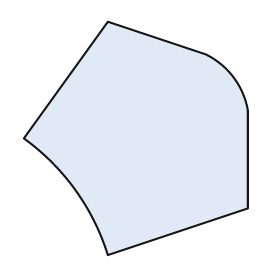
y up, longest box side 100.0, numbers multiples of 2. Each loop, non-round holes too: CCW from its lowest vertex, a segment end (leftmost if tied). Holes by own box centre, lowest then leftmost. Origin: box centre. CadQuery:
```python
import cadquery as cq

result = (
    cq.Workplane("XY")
    .moveTo(-12.0, -50.0)
    .lineTo(48.0, -30.0)
    .lineTo(48.0, 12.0)
    .threePointArc((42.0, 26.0), (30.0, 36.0))
    .lineTo(-12.0, 50.0)
    .lineTo(-48.0, 0.0)
    .threePointArc((-26.0, -22.0), (-12.0, -50.0))
    .close()
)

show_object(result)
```